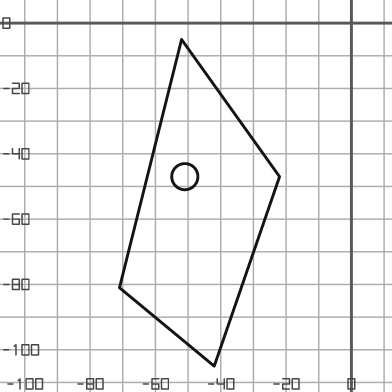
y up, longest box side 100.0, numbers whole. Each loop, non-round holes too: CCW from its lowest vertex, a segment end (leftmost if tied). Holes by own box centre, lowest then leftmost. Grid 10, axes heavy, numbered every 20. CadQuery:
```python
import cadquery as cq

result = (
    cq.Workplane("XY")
    .moveTo(-42.0, -105.0)
    .lineTo(-22.0, -47.0)
    .lineTo(-52.0, -5.0)
    .lineTo(-71.0, -81.0)
    .close()
    .moveTo(-51.0, -47.0)
    .circle(4.0)
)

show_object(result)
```